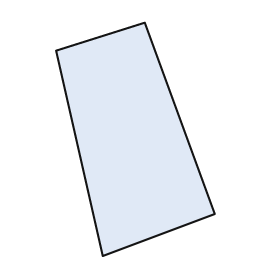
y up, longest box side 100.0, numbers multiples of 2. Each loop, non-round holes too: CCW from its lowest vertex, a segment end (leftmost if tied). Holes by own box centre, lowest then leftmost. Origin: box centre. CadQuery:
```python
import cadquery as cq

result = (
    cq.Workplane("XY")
    .moveTo(-14.0, -50.0)
    .lineTo(34.0, -32.0)
    .lineTo(4.0, 50.0)
    .lineTo(-34.0, 38.0)
    .close()
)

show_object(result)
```